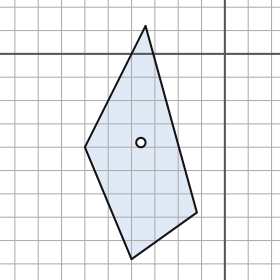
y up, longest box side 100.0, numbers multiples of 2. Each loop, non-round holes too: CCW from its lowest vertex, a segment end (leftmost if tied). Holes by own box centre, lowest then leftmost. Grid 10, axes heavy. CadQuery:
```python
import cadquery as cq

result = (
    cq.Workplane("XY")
    .moveTo(-40.0, -88.0)
    .lineTo(-12.0, -68.0)
    .lineTo(-34.0, 12.0)
    .lineTo(-60.0, -40.0)
    .close()
    .moveTo(-36.0, -38.0)
    .circle(2.0)
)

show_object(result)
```